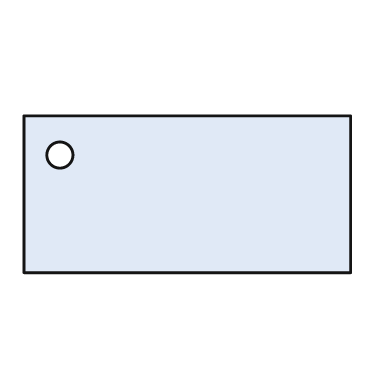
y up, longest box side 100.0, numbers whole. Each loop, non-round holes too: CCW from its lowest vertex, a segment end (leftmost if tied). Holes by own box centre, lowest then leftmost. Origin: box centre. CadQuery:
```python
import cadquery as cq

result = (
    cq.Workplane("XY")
    .moveTo(-50.0, -24.0)
    .lineTo(50.0, -24.0)
    .lineTo(50.0, 24.0)
    .lineTo(-50.0, 24.0)
    .close()
    .moveTo(-39.0, 12.0)
    .circle(4.0)
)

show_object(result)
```